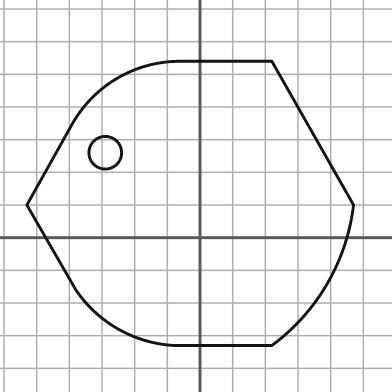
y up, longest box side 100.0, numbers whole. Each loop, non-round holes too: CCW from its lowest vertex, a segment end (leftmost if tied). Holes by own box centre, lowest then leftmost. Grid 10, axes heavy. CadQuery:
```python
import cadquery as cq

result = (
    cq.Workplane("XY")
    .moveTo(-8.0, -33.0)
    .lineTo(22.0, -33.0)
    .threePointArc((39.0, -14.0), (47.0, 10.0))
    .lineTo(22.0, 54.0)
    .lineTo(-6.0, 54.0)
    .threePointArc((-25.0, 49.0), (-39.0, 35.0))
    .lineTo(-53.0, 10.0)
    .lineTo(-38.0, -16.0)
    .threePointArc((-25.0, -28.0), (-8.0, -33.0))
    .close()
    .moveTo(-29.0, 26.0)
    .circle(5.0)
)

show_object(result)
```